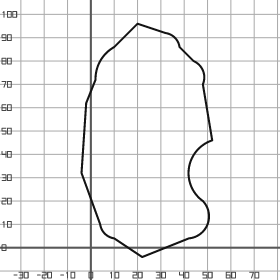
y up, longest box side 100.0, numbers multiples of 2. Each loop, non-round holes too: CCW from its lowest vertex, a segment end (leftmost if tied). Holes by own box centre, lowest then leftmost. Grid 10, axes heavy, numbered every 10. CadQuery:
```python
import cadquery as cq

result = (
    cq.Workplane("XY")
    .moveTo(22.0, -4.0)
    .lineTo(42.0, 4.0)
    .threePointArc((50.0, 10.0), (48.0, 20.0))
    .threePointArc((42.0, 34.0), (52.0, 46.0))
    .lineTo(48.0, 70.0)
    .threePointArc((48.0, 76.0), (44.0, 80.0))
    .lineTo(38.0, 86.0)
    .threePointArc((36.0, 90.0), (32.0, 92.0))
    .lineTo(20.0, 96.0)
    .lineTo(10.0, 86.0)
    .threePointArc((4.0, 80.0), (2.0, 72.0))
    .lineTo(-2.0, 62.0)
    .lineTo(-4.0, 32.0)
    .lineTo(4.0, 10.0)
    .threePointArc((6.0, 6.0), (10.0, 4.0))
    .close()
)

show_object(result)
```